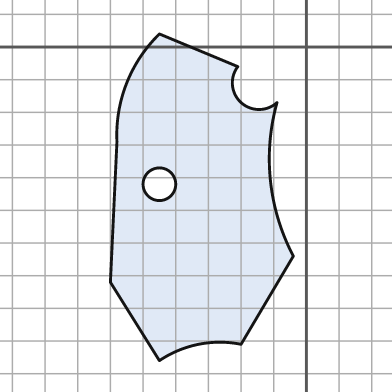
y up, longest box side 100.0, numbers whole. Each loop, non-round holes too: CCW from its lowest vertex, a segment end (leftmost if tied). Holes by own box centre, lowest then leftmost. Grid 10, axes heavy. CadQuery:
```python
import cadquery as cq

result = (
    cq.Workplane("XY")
    .moveTo(-45.0, -96.0)
    .threePointArc((-33.0, -91.0), (-20.0, -91.0))
    .lineTo(-4.0, -64.0)
    .threePointArc((-11.0, -41.0), (-9.0, -17.0))
    .threePointArc((-20.0, -17.0), (-21.0, -6.0))
    .lineTo(-45.0, 4.0)
    .threePointArc((-55.0, -11.0), (-58.0, -29.0))
    .lineTo(-60.0, -72.0)
    .close()
    .moveTo(-45.0, -42.0)
    .circle(5.0)
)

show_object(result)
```